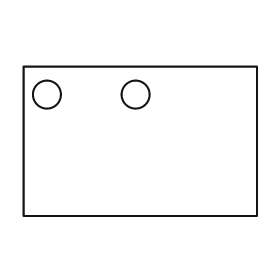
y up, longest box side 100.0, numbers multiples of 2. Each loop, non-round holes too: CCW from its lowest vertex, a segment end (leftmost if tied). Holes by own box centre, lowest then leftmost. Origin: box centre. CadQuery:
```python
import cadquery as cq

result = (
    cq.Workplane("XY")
    .moveTo(-50.0, -32.0)
    .lineTo(50.0, -32.0)
    .lineTo(50.0, 32.0)
    .lineTo(-50.0, 32.0)
    .close()
    .moveTo(-40.0, 20.0)
    .circle(6.0)
    .moveTo(-2.0, 20.0)
    .circle(6.0)
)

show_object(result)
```